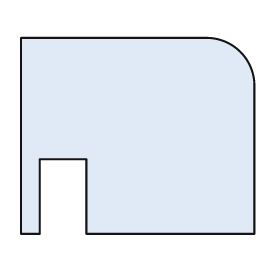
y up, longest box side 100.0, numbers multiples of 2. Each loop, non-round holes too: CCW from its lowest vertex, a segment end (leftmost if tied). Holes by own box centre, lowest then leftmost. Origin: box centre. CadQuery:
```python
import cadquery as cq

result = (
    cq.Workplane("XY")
    .moveTo(-50.0, -42.0)
    .lineTo(-42.0, -42.0)
    .lineTo(-42.0, -10.0)
    .lineTo(-22.0, -10.0)
    .lineTo(-22.0, -42.0)
    .lineTo(50.0, -42.0)
    .lineTo(50.0, 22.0)
    .threePointArc((44.0, 36.0), (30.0, 42.0))
    .lineTo(-50.0, 42.0)
    .close()
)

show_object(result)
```